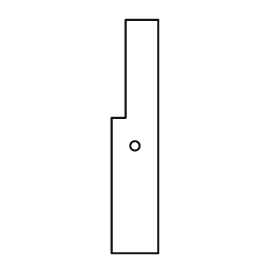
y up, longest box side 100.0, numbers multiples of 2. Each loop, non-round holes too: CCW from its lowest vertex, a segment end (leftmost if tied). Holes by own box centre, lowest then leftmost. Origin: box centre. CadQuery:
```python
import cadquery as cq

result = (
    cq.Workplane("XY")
    .moveTo(-10.0, -50.0)
    .lineTo(10.0, -50.0)
    .lineTo(10.0, 50.0)
    .lineTo(-4.0, 50.0)
    .lineTo(-4.0, 8.0)
    .lineTo(-10.0, 8.0)
    .close()
    .moveTo(0.0, -4.0)
    .circle(2.0)
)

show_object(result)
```